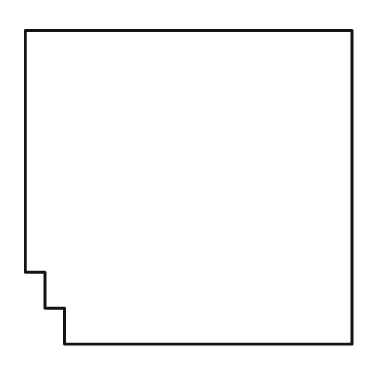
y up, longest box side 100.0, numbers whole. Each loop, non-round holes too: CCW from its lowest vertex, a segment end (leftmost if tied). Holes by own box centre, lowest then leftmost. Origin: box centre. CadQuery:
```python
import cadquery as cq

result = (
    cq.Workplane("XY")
    .moveTo(-38.0, -48.0)
    .lineTo(50.0, -48.0)
    .lineTo(50.0, 48.0)
    .lineTo(-50.0, 48.0)
    .lineTo(-50.0, -26.0)
    .lineTo(-44.0, -26.0)
    .lineTo(-44.0, -37.0)
    .lineTo(-38.0, -37.0)
    .close()
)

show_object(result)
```